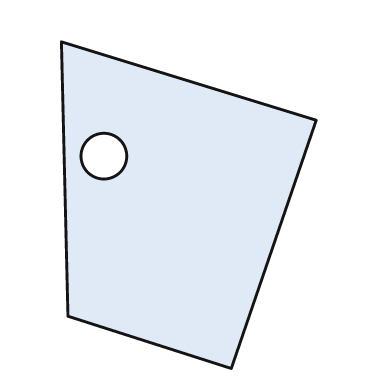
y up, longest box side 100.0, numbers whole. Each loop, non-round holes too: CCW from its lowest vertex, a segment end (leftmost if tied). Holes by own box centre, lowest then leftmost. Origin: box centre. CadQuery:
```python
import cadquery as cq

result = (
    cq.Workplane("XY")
    .moveTo(13.0, -50.0)
    .lineTo(39.0, 26.0)
    .lineTo(-39.0, 50.0)
    .lineTo(-37.0, -34.0)
    .close()
    .moveTo(-26.0, 15.0)
    .circle(7.0)
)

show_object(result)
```